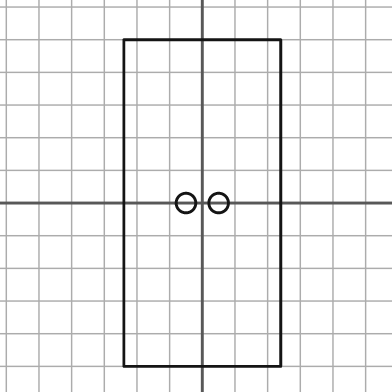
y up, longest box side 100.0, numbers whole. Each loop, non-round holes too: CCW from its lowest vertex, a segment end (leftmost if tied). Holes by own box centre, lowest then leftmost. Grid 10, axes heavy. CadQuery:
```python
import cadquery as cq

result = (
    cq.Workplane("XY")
    .moveTo(-24.0, -50.0)
    .lineTo(24.0, -50.0)
    .lineTo(24.0, 50.0)
    .lineTo(-24.0, 50.0)
    .close()
    .moveTo(-5.0, 0.0)
    .circle(3.0)
    .moveTo(5.0, 0.0)
    .circle(3.0)
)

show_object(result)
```